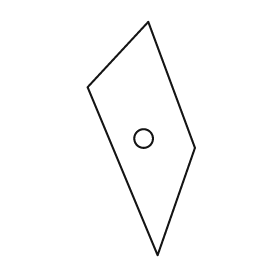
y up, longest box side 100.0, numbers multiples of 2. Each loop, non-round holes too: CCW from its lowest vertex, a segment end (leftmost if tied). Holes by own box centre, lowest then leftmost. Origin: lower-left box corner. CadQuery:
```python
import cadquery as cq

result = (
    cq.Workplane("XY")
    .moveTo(30.0, 0.0)
    .lineTo(46.0, 46.0)
    .lineTo(26.0, 100.0)
    .lineTo(0.0, 72.0)
    .close()
    .moveTo(24.0, 50.0)
    .circle(4.0)
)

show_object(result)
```